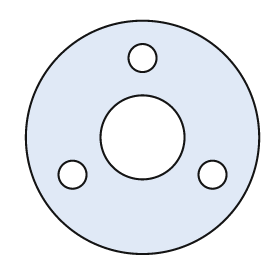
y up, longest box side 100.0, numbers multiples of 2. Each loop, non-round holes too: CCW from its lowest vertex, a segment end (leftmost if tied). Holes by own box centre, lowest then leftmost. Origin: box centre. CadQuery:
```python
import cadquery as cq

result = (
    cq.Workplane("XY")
    .moveTo(0.0, 0.0)
    .circle(50.0)
    .moveTo(-30.0, -16.0)
    .circle(6.0)
    .moveTo(30.0, -16.0)
    .circle(6.0)
    .moveTo(0.0, 0.0)
    .circle(18.0)
    .moveTo(0.0, 34.0)
    .circle(6.0)
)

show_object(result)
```